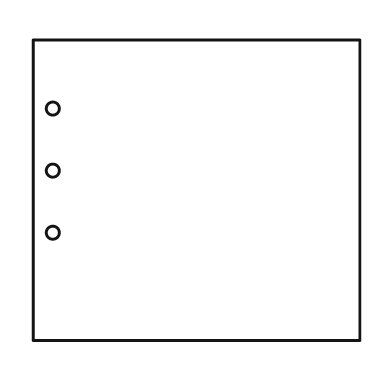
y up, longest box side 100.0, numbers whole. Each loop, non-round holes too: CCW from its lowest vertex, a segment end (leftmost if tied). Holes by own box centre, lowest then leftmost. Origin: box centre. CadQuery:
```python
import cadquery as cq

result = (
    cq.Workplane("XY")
    .moveTo(-50.0, -46.0)
    .lineTo(50.0, -46.0)
    .lineTo(50.0, 46.0)
    .lineTo(-50.0, 46.0)
    .close()
    .moveTo(-44.0, -13.0)
    .circle(2.0)
    .moveTo(-44.0, 6.0)
    .circle(2.0)
    .moveTo(-44.0, 25.0)
    .circle(2.0)
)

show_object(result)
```